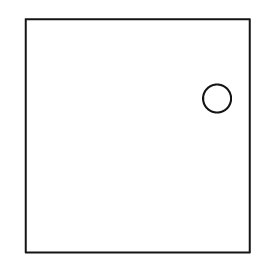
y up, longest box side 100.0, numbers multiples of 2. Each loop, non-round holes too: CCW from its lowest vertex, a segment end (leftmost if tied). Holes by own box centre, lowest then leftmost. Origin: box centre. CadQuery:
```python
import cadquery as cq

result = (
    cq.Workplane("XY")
    .moveTo(-48.0, -50.0)
    .lineTo(48.0, -50.0)
    .lineTo(48.0, 50.0)
    .lineTo(-48.0, 50.0)
    .close()
    .moveTo(34.0, 16.0)
    .circle(6.0)
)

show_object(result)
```